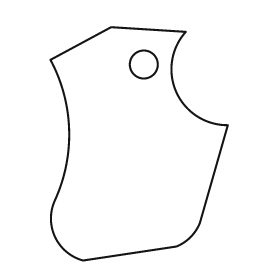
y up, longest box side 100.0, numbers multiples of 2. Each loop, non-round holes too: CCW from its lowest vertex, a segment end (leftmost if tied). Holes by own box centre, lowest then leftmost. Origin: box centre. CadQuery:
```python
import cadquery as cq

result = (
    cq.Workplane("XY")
    .moveTo(-24.0, -50.0)
    .lineTo(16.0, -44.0)
    .threePointArc((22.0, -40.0), (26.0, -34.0))
    .lineTo(38.0, 8.0)
    .threePointArc((16.0, 22.0), (20.0, 48.0))
    .lineTo(-12.0, 50.0)
    .lineTo(-38.0, 36.0)
    .threePointArc((-30.0, 6.0), (-36.0, -24.0))
    .threePointArc((-36.0, -40.0), (-24.0, -50.0))
    .close()
    .moveTo(2.0, 34.0)
    .circle(6.0)
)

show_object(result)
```